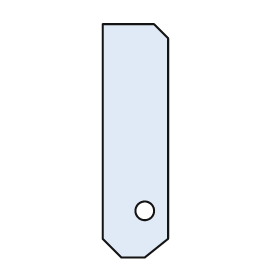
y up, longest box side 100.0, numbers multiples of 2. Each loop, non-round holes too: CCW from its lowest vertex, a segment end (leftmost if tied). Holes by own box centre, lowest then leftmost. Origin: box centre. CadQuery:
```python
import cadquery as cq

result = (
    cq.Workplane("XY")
    .moveTo(-6.0, -50.0)
    .lineTo(4.0, -50.0)
    .lineTo(14.0, -42.0)
    .lineTo(14.0, 44.0)
    .lineTo(8.0, 50.0)
    .lineTo(-14.0, 50.0)
    .lineTo(-14.0, -42.0)
    .close()
    .moveTo(4.0, -30.0)
    .circle(4.0)
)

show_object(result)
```